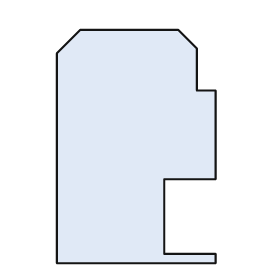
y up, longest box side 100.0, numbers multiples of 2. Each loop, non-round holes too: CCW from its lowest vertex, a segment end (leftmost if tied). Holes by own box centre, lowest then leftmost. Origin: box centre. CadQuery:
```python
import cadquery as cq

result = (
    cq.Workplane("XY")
    .moveTo(-34.0, -50.0)
    .lineTo(34.0, -50.0)
    .lineTo(34.0, -46.0)
    .lineTo(12.0, -46.0)
    .lineTo(12.0, -14.0)
    .lineTo(34.0, -14.0)
    .lineTo(34.0, 24.0)
    .lineTo(26.0, 24.0)
    .lineTo(26.0, 42.0)
    .lineTo(18.0, 50.0)
    .lineTo(-24.0, 50.0)
    .lineTo(-34.0, 40.0)
    .close()
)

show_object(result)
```